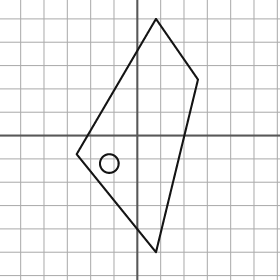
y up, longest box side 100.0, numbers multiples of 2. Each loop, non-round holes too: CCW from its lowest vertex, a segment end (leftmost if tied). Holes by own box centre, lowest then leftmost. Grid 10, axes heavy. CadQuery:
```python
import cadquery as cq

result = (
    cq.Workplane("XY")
    .moveTo(8.0, -50.0)
    .lineTo(26.0, 24.0)
    .lineTo(8.0, 50.0)
    .lineTo(-26.0, -8.0)
    .close()
    .moveTo(-12.0, -12.0)
    .circle(4.0)
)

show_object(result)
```